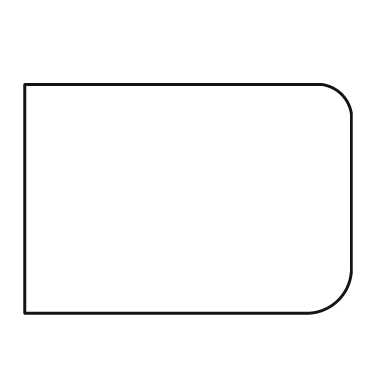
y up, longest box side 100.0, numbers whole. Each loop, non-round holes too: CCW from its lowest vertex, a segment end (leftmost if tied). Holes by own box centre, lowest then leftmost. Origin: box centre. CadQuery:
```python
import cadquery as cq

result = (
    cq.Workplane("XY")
    .moveTo(-50.0, -35.0)
    .lineTo(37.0, -35.0)
    .threePointArc((46.0, -31.0), (50.0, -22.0))
    .lineTo(50.0, 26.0)
    .threePointArc((47.0, 32.0), (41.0, 35.0))
    .lineTo(-50.0, 35.0)
    .close()
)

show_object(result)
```